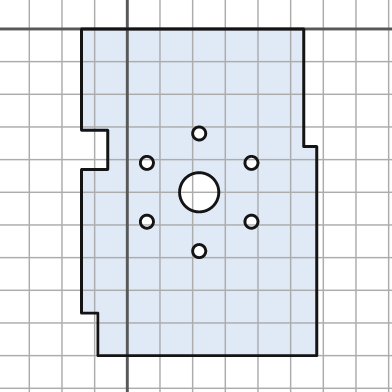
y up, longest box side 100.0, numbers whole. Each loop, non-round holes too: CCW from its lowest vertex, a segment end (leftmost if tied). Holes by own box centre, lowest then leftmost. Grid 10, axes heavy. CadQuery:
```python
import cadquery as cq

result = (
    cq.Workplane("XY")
    .moveTo(-9.0, -100.0)
    .lineTo(58.0, -100.0)
    .lineTo(58.0, -36.0)
    .lineTo(54.0, -36.0)
    .lineTo(54.0, 0.0)
    .lineTo(-14.0, 0.0)
    .lineTo(-14.0, -31.0)
    .lineTo(-6.0, -31.0)
    .lineTo(-6.0, -43.0)
    .lineTo(-14.0, -43.0)
    .lineTo(-14.0, -87.0)
    .lineTo(-9.0, -87.0)
    .close()
    .moveTo(22.0, -68.0)
    .circle(2.0)
    .moveTo(6.0, -59.0)
    .circle(2.0)
    .moveTo(38.0, -59.0)
    .circle(2.0)
    .moveTo(22.0, -50.0)
    .circle(6.0)
    .moveTo(6.0, -41.0)
    .circle(2.0)
    .moveTo(38.0, -41.0)
    .circle(2.0)
    .moveTo(22.0, -32.0)
    .circle(2.0)
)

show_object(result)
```